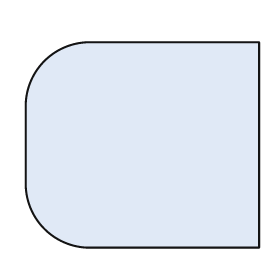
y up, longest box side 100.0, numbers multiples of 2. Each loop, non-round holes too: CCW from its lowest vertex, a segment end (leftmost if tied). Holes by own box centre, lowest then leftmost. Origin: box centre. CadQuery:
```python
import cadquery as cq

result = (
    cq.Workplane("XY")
    .moveTo(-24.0, -44.0)
    .lineTo(50.0, -44.0)
    .lineTo(50.0, 44.0)
    .lineTo(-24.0, 44.0)
    .threePointArc((-42.0, 36.0), (-50.0, 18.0))
    .lineTo(-50.0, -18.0)
    .threePointArc((-42.0, -36.0), (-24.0, -44.0))
    .close()
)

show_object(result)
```